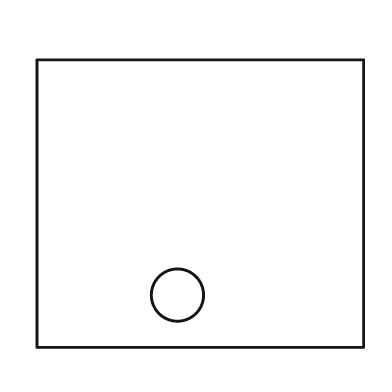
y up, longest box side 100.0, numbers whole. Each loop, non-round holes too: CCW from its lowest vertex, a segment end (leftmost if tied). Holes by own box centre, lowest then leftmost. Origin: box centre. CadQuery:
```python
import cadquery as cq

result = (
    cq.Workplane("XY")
    .moveTo(-50.0, -44.0)
    .lineTo(50.0, -44.0)
    .lineTo(50.0, 44.0)
    .lineTo(-50.0, 44.0)
    .close()
    .moveTo(-7.0, -28.0)
    .circle(8.0)
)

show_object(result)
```